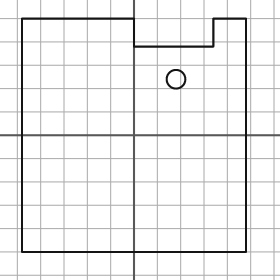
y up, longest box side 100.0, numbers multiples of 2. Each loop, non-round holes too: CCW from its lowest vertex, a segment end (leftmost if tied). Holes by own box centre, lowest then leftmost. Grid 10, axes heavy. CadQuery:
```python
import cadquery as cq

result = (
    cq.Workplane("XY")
    .moveTo(-48.0, -50.0)
    .lineTo(48.0, -50.0)
    .lineTo(48.0, 50.0)
    .lineTo(34.0, 50.0)
    .lineTo(34.0, 38.0)
    .lineTo(0.0, 38.0)
    .lineTo(0.0, 50.0)
    .lineTo(-48.0, 50.0)
    .close()
    .moveTo(18.0, 24.0)
    .circle(4.0)
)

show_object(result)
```